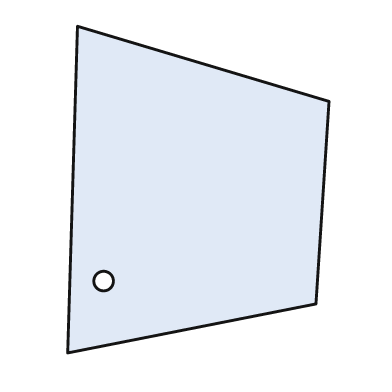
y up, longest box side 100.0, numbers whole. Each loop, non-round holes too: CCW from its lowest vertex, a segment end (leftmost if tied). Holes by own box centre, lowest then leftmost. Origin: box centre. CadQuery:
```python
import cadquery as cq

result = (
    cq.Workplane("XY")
    .moveTo(-40.0, -50.0)
    .lineTo(36.0, -35.0)
    .lineTo(40.0, 27.0)
    .lineTo(-37.0, 50.0)
    .close()
    .moveTo(-29.0, -28.0)
    .circle(3.0)
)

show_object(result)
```